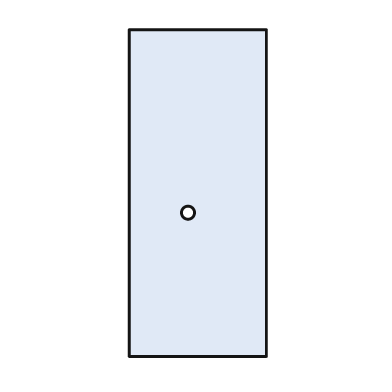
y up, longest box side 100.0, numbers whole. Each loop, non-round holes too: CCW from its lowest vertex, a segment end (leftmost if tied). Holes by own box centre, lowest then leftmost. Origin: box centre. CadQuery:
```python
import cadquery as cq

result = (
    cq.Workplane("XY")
    .moveTo(-21.0, -50.0)
    .lineTo(21.0, -50.0)
    .lineTo(21.0, 50.0)
    .lineTo(-21.0, 50.0)
    .close()
    .moveTo(-3.0, -6.0)
    .circle(2.0)
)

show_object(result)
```